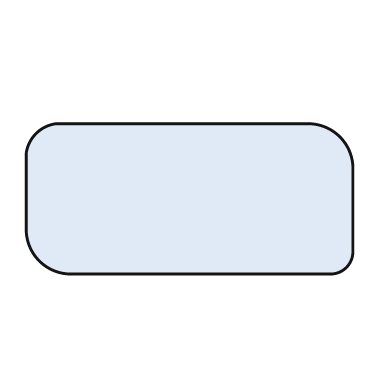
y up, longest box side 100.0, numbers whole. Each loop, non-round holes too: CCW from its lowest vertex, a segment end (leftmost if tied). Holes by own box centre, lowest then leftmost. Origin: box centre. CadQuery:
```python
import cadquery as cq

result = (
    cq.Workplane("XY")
    .moveTo(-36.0, -23.0)
    .lineTo(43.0, -23.0)
    .threePointArc((48.0, -21.0), (50.0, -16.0))
    .lineTo(50.0, 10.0)
    .threePointArc((46.0, 19.0), (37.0, 23.0))
    .lineTo(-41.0, 23.0)
    .threePointArc((-47.0, 20.0), (-50.0, 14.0))
    .lineTo(-50.0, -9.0)
    .threePointArc((-46.0, -19.0), (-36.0, -23.0))
    .close()
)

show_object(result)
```